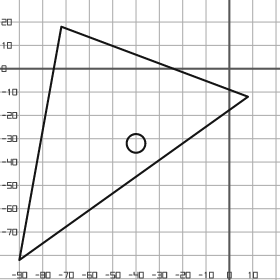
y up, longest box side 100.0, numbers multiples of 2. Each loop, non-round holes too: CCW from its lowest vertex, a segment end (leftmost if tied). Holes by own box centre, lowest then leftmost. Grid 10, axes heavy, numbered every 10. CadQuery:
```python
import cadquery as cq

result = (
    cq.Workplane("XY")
    .moveTo(-90.0, -82.0)
    .lineTo(8.0, -12.0)
    .lineTo(-72.0, 18.0)
    .close()
    .moveTo(-40.0, -32.0)
    .circle(4.0)
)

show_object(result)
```